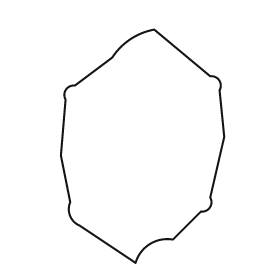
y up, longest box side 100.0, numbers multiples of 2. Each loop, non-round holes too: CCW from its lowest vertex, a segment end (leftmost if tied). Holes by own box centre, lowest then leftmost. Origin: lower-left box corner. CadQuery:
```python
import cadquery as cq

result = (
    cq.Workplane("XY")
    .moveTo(32.0, 0.0)
    .threePointArc((38.0, 8.0), (48.0, 10.0))
    .lineTo(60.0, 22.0)
    .threePointArc((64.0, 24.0), (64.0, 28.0))
    .lineTo(70.0, 54.0)
    .lineTo(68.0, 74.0)
    .threePointArc((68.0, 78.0), (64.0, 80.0))
    .lineTo(40.0, 100.0)
    .threePointArc((30.0, 96.0), (22.0, 88.0))
    .lineTo(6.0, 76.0)
    .threePointArc((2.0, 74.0), (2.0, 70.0))
    .lineTo(0.0, 46.0)
    .lineTo(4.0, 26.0)
    .threePointArc((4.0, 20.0), (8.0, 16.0))
    .close()
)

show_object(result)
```